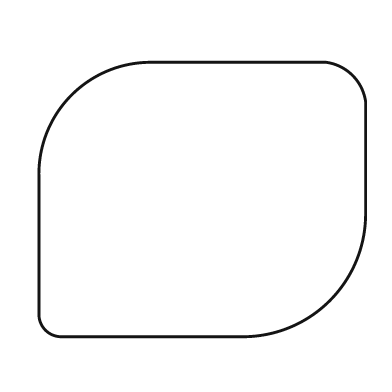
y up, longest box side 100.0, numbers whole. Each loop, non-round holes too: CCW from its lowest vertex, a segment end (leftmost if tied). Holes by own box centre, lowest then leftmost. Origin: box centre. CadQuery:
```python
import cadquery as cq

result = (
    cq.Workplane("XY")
    .moveTo(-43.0, -42.0)
    .lineTo(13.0, -42.0)
    .threePointArc((39.0, -31.0), (50.0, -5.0))
    .lineTo(50.0, 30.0)
    .threePointArc((46.0, 38.0), (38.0, 42.0))
    .lineTo(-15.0, 42.0)
    .threePointArc((-40.0, 32.0), (-50.0, 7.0))
    .lineTo(-50.0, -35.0)
    .threePointArc((-48.0, -40.0), (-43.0, -42.0))
    .close()
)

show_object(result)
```